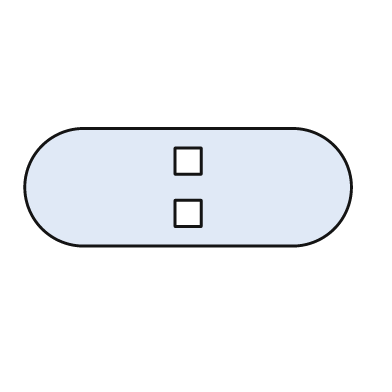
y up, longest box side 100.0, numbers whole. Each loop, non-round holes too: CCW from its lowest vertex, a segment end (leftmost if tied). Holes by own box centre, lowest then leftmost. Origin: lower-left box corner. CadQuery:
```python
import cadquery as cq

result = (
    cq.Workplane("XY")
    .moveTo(18.0, 0.0)
    .lineTo(82.0, 0.0)
    .threePointArc((100.0, 18.0), (82.0, 36.0))
    .lineTo(18.0, 36.0)
    .threePointArc((0.0, 18.0), (18.0, 0.0))
    .close()
    .moveTo(46.0, 6.0)
    .lineTo(54.0, 6.0)
    .lineTo(54.0, 14.0)
    .lineTo(46.0, 14.0)
    .close()
    .moveTo(46.0, 22.0)
    .lineTo(54.0, 22.0)
    .lineTo(54.0, 30.0)
    .lineTo(46.0, 30.0)
    .close()
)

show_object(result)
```